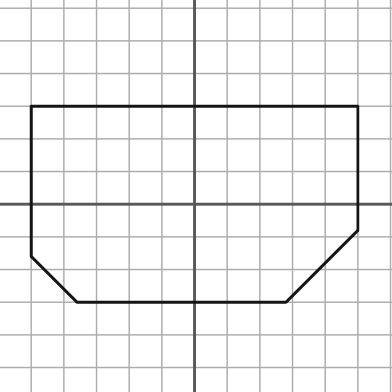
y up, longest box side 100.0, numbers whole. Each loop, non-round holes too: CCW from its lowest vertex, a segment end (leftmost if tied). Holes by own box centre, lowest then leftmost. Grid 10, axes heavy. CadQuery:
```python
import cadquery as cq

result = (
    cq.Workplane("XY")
    .moveTo(-36.0, -30.0)
    .lineTo(28.0, -30.0)
    .lineTo(50.0, -8.0)
    .lineTo(50.0, 30.0)
    .lineTo(-50.0, 30.0)
    .lineTo(-50.0, -16.0)
    .close()
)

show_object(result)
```